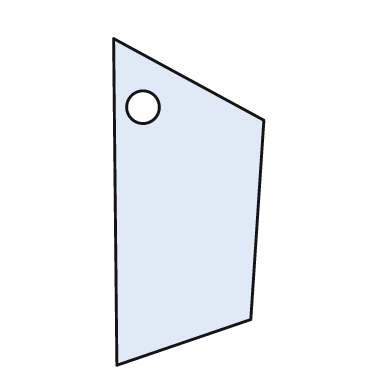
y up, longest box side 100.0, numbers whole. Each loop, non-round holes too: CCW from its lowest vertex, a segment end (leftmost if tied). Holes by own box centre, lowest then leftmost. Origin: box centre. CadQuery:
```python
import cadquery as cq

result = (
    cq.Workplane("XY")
    .moveTo(-22.0, -50.0)
    .lineTo(19.0, -36.0)
    .lineTo(23.0, 25.0)
    .lineTo(-23.0, 50.0)
    .close()
    .moveTo(-14.0, 29.0)
    .circle(5.0)
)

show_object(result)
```